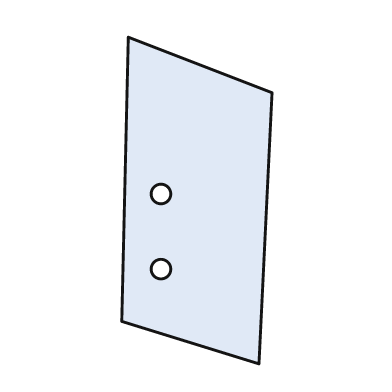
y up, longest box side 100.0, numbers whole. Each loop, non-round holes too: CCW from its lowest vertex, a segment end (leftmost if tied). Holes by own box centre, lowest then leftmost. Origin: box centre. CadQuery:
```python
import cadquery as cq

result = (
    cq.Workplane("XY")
    .moveTo(19.0, -50.0)
    .lineTo(23.0, 33.0)
    .lineTo(-21.0, 50.0)
    .lineTo(-23.0, -37.0)
    .close()
    .moveTo(-11.0, -21.0)
    .circle(3.0)
    .moveTo(-11.0, 2.0)
    .circle(3.0)
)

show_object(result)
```